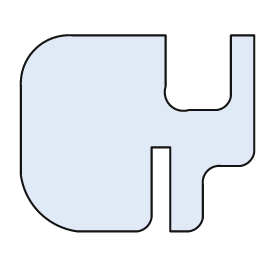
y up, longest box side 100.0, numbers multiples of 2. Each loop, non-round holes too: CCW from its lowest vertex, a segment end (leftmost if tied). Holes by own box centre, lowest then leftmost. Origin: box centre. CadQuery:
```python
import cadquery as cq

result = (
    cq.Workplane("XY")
    .moveTo(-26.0, -42.0)
    .lineTo(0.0, -42.0)
    .threePointArc((4.0, -40.0), (6.0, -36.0))
    .lineTo(6.0, -6.0)
    .lineTo(14.0, -6.0)
    .lineTo(14.0, -42.0)
    .lineTo(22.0, -42.0)
    .threePointArc((26.0, -40.0), (28.0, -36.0))
    .lineTo(28.0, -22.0)
    .threePointArc((30.0, -16.0), (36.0, -14.0))
    .lineTo(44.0, -14.0)
    .threePointArc((48.0, -12.0), (50.0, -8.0))
    .lineTo(50.0, 42.0)
    .lineTo(40.0, 42.0)
    .lineTo(40.0, 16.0)
    .threePointArc((38.0, 12.0), (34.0, 10.0))
    .lineTo(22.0, 10.0)
    .threePointArc((14.0, 12.0), (12.0, 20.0))
    .lineTo(12.0, 42.0)
    .lineTo(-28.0, 42.0)
    .threePointArc((-44.0, 36.0), (-50.0, 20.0))
    .lineTo(-50.0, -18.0)
    .threePointArc((-42.0, -34.0), (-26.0, -42.0))
    .close()
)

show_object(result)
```